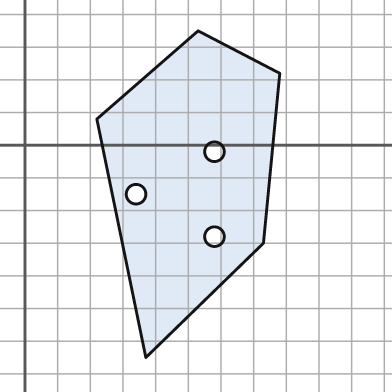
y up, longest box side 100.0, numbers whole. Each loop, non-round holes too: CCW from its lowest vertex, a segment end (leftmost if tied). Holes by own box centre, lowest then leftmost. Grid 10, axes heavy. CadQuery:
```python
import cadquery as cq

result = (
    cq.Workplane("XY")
    .moveTo(37.0, -65.0)
    .lineTo(73.0, -30.0)
    .lineTo(78.0, 22.0)
    .lineTo(53.0, 35.0)
    .lineTo(22.0, 8.0)
    .close()
    .moveTo(58.0, -28.0)
    .circle(3.0)
    .moveTo(34.0, -15.0)
    .circle(3.0)
    .moveTo(58.0, -2.0)
    .circle(3.0)
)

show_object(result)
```